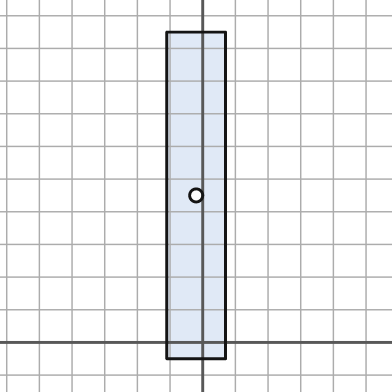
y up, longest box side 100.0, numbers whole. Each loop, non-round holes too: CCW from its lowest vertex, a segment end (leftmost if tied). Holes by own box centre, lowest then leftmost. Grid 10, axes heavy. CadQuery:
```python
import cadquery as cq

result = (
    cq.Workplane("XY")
    .moveTo(-11.0, -5.0)
    .lineTo(7.0, -5.0)
    .lineTo(7.0, 95.0)
    .lineTo(-11.0, 95.0)
    .close()
    .moveTo(-2.0, 45.0)
    .circle(2.0)
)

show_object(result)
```